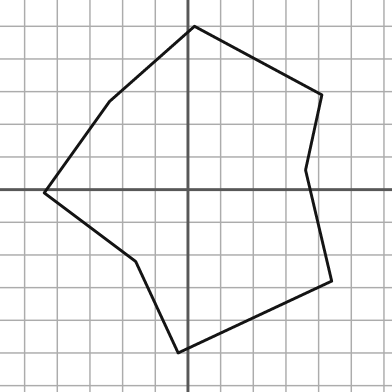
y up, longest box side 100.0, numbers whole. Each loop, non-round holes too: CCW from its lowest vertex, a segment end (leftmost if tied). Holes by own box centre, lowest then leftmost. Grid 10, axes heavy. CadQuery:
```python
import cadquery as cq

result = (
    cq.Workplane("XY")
    .moveTo(-3.0, -50.0)
    .lineTo(44.0, -28.0)
    .lineTo(36.0, 6.0)
    .lineTo(41.0, 29.0)
    .lineTo(2.0, 50.0)
    .lineTo(-24.0, 27.0)
    .lineTo(-44.0, -1.0)
    .lineTo(-16.0, -22.0)
    .close()
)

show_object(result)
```